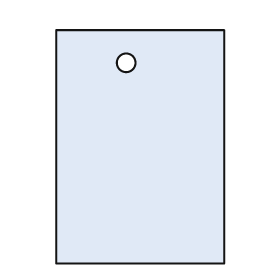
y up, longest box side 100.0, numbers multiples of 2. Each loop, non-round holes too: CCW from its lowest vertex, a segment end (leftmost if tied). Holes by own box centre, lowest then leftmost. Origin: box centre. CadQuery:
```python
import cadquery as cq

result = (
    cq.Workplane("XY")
    .moveTo(-36.0, -50.0)
    .lineTo(36.0, -50.0)
    .lineTo(36.0, 50.0)
    .lineTo(-36.0, 50.0)
    .close()
    .moveTo(-6.0, 36.0)
    .circle(4.0)
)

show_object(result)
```